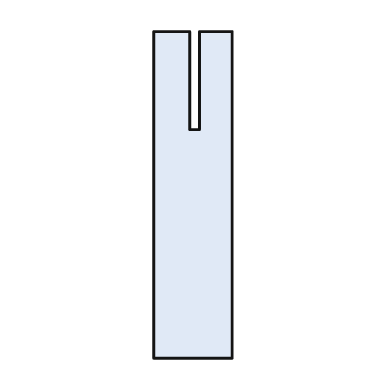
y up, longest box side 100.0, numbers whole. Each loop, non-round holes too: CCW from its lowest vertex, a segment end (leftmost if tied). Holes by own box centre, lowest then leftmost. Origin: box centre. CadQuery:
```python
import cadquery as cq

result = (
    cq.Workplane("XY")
    .moveTo(-12.0, -50.0)
    .lineTo(12.0, -50.0)
    .lineTo(12.0, 50.0)
    .lineTo(2.0, 50.0)
    .lineTo(2.0, 20.0)
    .lineTo(-1.0, 20.0)
    .lineTo(-1.0, 50.0)
    .lineTo(-12.0, 50.0)
    .close()
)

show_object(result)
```